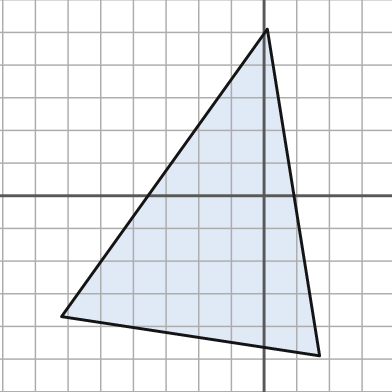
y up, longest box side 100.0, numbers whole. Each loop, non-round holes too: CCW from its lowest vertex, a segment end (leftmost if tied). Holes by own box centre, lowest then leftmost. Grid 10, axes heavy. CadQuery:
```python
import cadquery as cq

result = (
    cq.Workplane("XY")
    .moveTo(17.0, -49.0)
    .lineTo(1.0, 51.0)
    .lineTo(-62.0, -37.0)
    .close()
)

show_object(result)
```